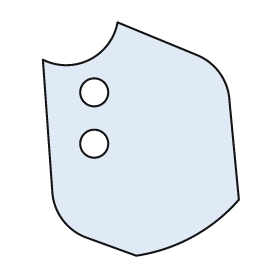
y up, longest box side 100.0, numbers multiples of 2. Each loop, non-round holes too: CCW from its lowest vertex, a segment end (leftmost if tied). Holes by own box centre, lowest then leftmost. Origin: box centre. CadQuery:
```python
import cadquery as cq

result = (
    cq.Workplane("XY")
    .moveTo(-2.0, -50.0)
    .threePointArc((22.0, -42.0), (42.0, -26.0))
    .lineTo(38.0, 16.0)
    .threePointArc((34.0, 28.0), (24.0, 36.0))
    .lineTo(-10.0, 50.0)
    .threePointArc((-22.0, 34.0), (-42.0, 34.0))
    .lineTo(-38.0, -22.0)
    .threePointArc((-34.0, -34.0), (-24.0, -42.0))
    .close()
    .moveTo(-20.0, -2.0)
    .circle(6.0)
    .moveTo(-20.0, 20.0)
    .circle(6.0)
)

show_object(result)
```